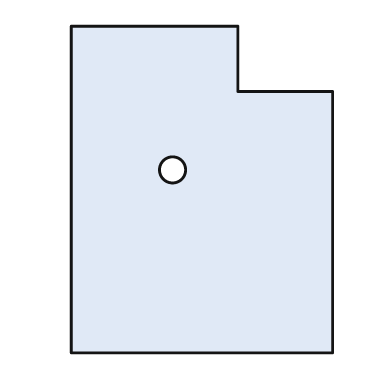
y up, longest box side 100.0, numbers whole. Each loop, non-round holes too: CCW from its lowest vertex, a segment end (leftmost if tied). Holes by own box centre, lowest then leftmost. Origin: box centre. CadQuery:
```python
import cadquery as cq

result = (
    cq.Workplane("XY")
    .moveTo(-40.0, -50.0)
    .lineTo(40.0, -50.0)
    .lineTo(40.0, 30.0)
    .lineTo(11.0, 30.0)
    .lineTo(11.0, 50.0)
    .lineTo(-40.0, 50.0)
    .close()
    .moveTo(-9.0, 6.0)
    .circle(4.0)
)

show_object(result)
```